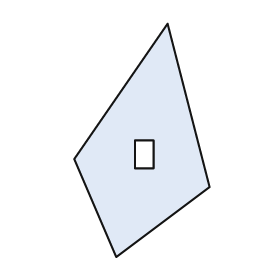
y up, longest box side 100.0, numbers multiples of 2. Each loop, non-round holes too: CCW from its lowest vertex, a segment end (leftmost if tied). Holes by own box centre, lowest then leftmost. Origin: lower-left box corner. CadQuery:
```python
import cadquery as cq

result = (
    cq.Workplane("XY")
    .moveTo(18.0, 0.0)
    .lineTo(58.0, 30.0)
    .lineTo(40.0, 100.0)
    .lineTo(0.0, 42.0)
    .close()
    .moveTo(26.0, 38.0)
    .lineTo(34.0, 38.0)
    .lineTo(34.0, 50.0)
    .lineTo(26.0, 50.0)
    .close()
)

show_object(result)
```